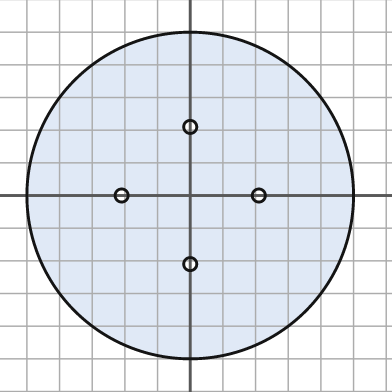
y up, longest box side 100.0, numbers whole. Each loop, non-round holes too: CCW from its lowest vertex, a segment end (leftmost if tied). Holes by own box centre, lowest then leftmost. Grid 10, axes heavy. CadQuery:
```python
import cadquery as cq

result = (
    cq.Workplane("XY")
    .moveTo(0.0, 0.0)
    .circle(50.0)
    .moveTo(0.0, -21.0)
    .circle(2.0)
    .moveTo(-21.0, 0.0)
    .circle(2.0)
    .moveTo(21.0, 0.0)
    .circle(2.0)
    .moveTo(0.0, 21.0)
    .circle(2.0)
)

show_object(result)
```